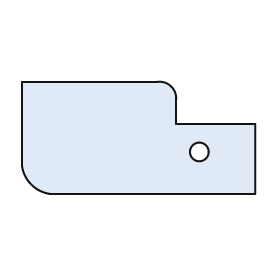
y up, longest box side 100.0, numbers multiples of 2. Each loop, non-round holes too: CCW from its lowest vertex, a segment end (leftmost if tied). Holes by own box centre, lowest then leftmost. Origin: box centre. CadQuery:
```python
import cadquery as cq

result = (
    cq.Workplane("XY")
    .moveTo(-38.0, -24.0)
    .lineTo(50.0, -24.0)
    .lineTo(50.0, 6.0)
    .lineTo(16.0, 6.0)
    .lineTo(16.0, 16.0)
    .threePointArc((14.0, 22.0), (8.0, 24.0))
    .lineTo(-50.0, 24.0)
    .lineTo(-50.0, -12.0)
    .threePointArc((-46.0, -20.0), (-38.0, -24.0))
    .close()
    .moveTo(26.0, -6.0)
    .circle(4.0)
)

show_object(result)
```